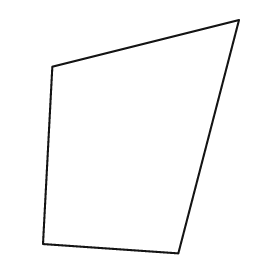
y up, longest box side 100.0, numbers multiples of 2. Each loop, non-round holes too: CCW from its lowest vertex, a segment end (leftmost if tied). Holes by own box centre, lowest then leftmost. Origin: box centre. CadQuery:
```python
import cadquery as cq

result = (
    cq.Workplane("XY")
    .moveTo(16.0, -50.0)
    .lineTo(42.0, 50.0)
    .lineTo(-38.0, 30.0)
    .lineTo(-42.0, -46.0)
    .close()
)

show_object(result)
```